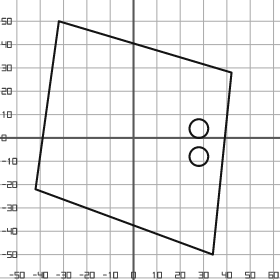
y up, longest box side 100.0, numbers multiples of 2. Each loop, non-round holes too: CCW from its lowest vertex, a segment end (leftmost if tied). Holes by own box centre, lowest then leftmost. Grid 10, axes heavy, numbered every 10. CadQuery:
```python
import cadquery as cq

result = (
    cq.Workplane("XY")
    .moveTo(34.0, -50.0)
    .lineTo(42.0, 28.0)
    .lineTo(-32.0, 50.0)
    .lineTo(-42.0, -22.0)
    .close()
    .moveTo(28.0, -8.0)
    .circle(4.0)
    .moveTo(28.0, 4.0)
    .circle(4.0)
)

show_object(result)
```